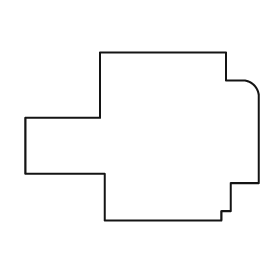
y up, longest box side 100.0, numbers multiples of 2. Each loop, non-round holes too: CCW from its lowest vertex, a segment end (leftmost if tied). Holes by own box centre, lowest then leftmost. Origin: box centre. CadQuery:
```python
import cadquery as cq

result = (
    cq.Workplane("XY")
    .moveTo(-16.0, -36.0)
    .lineTo(34.0, -36.0)
    .lineTo(34.0, -32.0)
    .lineTo(38.0, -32.0)
    .lineTo(38.0, -20.0)
    .lineTo(50.0, -20.0)
    .lineTo(50.0, 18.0)
    .threePointArc((48.0, 22.0), (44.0, 24.0))
    .lineTo(36.0, 24.0)
    .lineTo(36.0, 36.0)
    .lineTo(-18.0, 36.0)
    .lineTo(-18.0, 8.0)
    .lineTo(-50.0, 8.0)
    .lineTo(-50.0, -16.0)
    .lineTo(-16.0, -16.0)
    .close()
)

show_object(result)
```